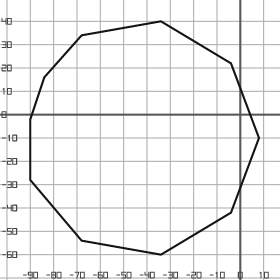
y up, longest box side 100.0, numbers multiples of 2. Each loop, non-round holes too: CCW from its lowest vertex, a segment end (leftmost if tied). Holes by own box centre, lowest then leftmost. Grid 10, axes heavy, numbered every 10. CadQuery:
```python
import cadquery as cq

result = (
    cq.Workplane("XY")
    .moveTo(-34.0, -60.0)
    .lineTo(-4.0, -42.0)
    .lineTo(8.0, -10.0)
    .lineTo(-4.0, 22.0)
    .lineTo(-34.0, 40.0)
    .lineTo(-68.0, 34.0)
    .lineTo(-84.0, 16.0)
    .lineTo(-90.0, -2.0)
    .lineTo(-90.0, -28.0)
    .lineTo(-68.0, -54.0)
    .close()
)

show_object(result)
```